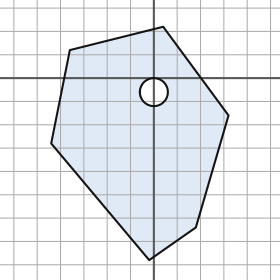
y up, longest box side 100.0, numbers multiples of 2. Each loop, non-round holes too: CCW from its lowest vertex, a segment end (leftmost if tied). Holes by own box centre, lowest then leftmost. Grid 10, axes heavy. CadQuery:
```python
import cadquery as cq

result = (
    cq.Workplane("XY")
    .moveTo(-2.0, -78.0)
    .lineTo(18.0, -64.0)
    .lineTo(32.0, -16.0)
    .lineTo(4.0, 22.0)
    .lineTo(-36.0, 12.0)
    .lineTo(-44.0, -28.0)
    .close()
    .moveTo(0.0, -6.0)
    .circle(6.0)
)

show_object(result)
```